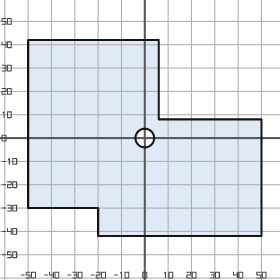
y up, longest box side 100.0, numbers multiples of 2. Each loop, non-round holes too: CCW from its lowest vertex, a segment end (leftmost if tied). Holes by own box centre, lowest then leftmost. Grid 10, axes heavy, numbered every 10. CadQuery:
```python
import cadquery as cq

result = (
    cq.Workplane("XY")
    .moveTo(-20.0, -42.0)
    .lineTo(50.0, -42.0)
    .lineTo(50.0, 8.0)
    .lineTo(6.0, 8.0)
    .lineTo(6.0, 42.0)
    .lineTo(-50.0, 42.0)
    .lineTo(-50.0, -30.0)
    .lineTo(-20.0, -30.0)
    .close()
    .moveTo(0.0, 0.0)
    .circle(4.0)
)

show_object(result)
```